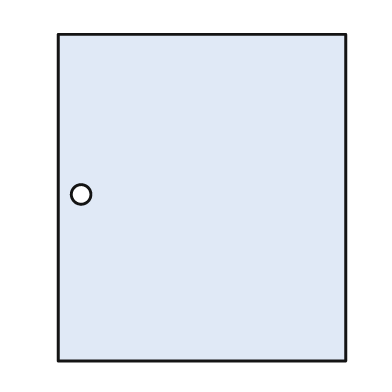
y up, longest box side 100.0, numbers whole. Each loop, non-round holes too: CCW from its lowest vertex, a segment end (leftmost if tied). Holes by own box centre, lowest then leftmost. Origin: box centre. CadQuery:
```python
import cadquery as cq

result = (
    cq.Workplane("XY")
    .moveTo(-44.0, -50.0)
    .lineTo(44.0, -50.0)
    .lineTo(44.0, 50.0)
    .lineTo(-44.0, 50.0)
    .close()
    .moveTo(-37.0, 1.0)
    .circle(3.0)
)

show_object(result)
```